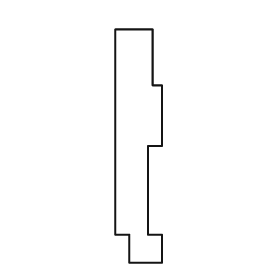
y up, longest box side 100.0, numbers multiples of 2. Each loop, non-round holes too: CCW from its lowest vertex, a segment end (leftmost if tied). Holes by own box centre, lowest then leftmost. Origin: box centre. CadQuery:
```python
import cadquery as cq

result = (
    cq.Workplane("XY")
    .moveTo(-4.0, -50.0)
    .lineTo(10.0, -50.0)
    .lineTo(10.0, -38.0)
    .lineTo(4.0, -38.0)
    .lineTo(4.0, 0.0)
    .lineTo(10.0, 0.0)
    .lineTo(10.0, 26.0)
    .lineTo(6.0, 26.0)
    .lineTo(6.0, 50.0)
    .lineTo(-10.0, 50.0)
    .lineTo(-10.0, -38.0)
    .lineTo(-4.0, -38.0)
    .close()
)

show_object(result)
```